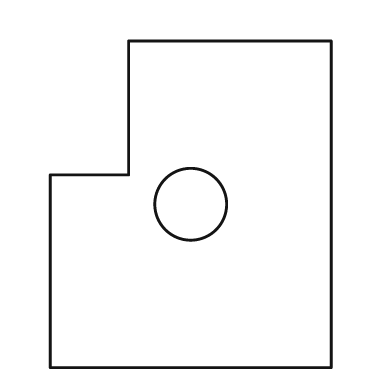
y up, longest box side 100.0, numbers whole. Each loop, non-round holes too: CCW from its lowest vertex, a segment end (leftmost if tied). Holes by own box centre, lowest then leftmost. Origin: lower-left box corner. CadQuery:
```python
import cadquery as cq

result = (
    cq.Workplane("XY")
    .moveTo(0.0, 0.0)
    .lineTo(86.0, 0.0)
    .lineTo(86.0, 100.0)
    .lineTo(24.0, 100.0)
    .lineTo(24.0, 59.0)
    .lineTo(0.0, 59.0)
    .close()
    .moveTo(43.0, 50.0)
    .circle(11.0)
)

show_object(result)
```